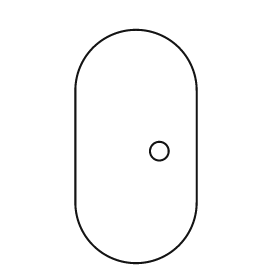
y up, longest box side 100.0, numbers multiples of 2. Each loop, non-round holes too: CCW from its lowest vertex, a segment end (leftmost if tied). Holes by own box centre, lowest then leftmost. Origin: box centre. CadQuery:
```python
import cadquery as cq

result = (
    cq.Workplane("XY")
    .moveTo(-26.0, -24.0)
    .threePointArc((0.0, -50.0), (26.0, -24.0))
    .lineTo(26.0, 24.0)
    .threePointArc((0.0, 50.0), (-26.0, 24.0))
    .close()
    .moveTo(10.0, -2.0)
    .circle(4.0)
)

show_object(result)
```